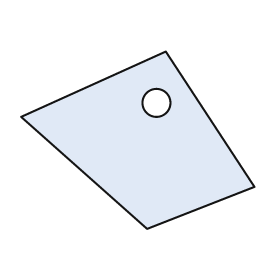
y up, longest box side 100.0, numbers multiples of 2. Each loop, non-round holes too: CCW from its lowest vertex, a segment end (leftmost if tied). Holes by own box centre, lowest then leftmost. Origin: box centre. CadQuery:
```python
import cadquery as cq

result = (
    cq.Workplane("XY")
    .moveTo(4.0, -38.0)
    .lineTo(50.0, -20.0)
    .lineTo(12.0, 38.0)
    .lineTo(-50.0, 10.0)
    .close()
    .moveTo(8.0, 16.0)
    .circle(6.0)
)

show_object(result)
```